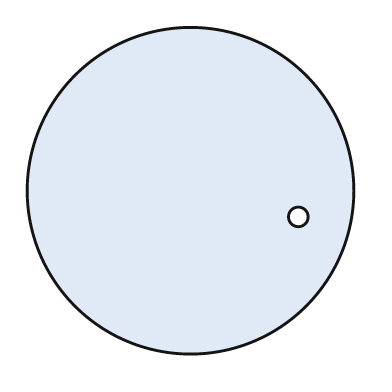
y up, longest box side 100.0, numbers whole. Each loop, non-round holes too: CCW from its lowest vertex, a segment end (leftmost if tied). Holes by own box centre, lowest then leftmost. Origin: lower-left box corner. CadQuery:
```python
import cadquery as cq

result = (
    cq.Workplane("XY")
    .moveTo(50.0, 50.0)
    .circle(50.0)
    .moveTo(83.0, 42.0)
    .circle(3.0)
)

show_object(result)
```